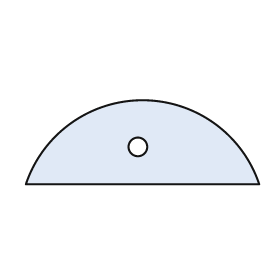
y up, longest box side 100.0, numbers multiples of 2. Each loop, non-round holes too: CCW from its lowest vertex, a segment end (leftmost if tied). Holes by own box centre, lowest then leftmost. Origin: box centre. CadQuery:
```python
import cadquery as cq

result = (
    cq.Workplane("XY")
    .moveTo(-50.0, -18.0)
    .lineTo(50.0, -18.0)
    .threePointArc((0.0, 18.0), (-50.0, -18.0))
    .close()
    .moveTo(-2.0, -2.0)
    .circle(4.0)
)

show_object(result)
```